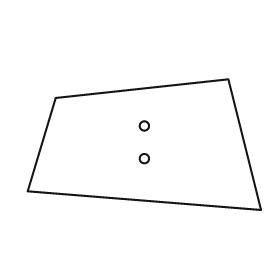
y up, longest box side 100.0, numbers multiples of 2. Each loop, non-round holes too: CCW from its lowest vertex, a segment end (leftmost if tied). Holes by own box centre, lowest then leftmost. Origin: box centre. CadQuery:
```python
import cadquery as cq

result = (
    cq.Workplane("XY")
    .moveTo(50.0, -28.0)
    .lineTo(36.0, 28.0)
    .lineTo(-38.0, 20.0)
    .lineTo(-50.0, -20.0)
    .close()
    .moveTo(0.0, -6.0)
    .circle(2.0)
    .moveTo(0.0, 8.0)
    .circle(2.0)
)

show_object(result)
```